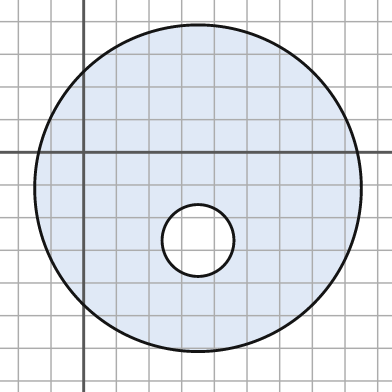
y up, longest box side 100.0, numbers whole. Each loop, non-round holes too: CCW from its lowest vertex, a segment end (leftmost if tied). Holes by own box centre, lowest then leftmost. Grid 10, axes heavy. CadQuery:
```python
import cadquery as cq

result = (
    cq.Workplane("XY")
    .moveTo(35.0, -11.0)
    .circle(50.0)
    .moveTo(35.0, -27.0)
    .circle(11.0)
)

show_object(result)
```